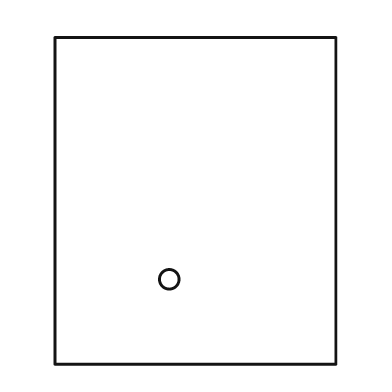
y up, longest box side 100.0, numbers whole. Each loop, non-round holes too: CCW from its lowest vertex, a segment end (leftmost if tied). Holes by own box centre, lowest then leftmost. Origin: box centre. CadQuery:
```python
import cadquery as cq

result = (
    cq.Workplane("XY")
    .moveTo(-43.0, -50.0)
    .lineTo(43.0, -50.0)
    .lineTo(43.0, 50.0)
    .lineTo(-43.0, 50.0)
    .close()
    .moveTo(-8.0, -24.0)
    .circle(3.0)
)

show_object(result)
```